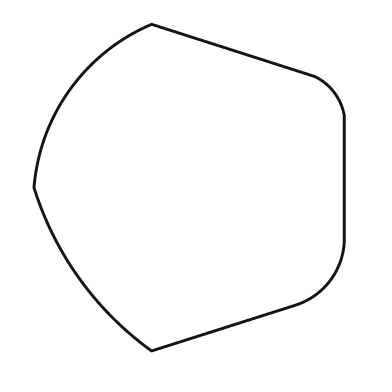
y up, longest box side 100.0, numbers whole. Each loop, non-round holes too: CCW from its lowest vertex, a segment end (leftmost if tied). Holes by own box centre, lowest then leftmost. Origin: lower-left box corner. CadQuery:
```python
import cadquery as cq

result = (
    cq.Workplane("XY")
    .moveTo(36.0, 0.0)
    .lineTo(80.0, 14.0)
    .threePointArc((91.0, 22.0), (95.0, 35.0))
    .lineTo(95.0, 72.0)
    .threePointArc((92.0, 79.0), (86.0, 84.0))
    .lineTo(36.0, 100.0)
    .threePointArc((11.0, 80.0), (0.0, 50.0))
    .threePointArc((14.0, 22.0), (36.0, 0.0))
    .close()
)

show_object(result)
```